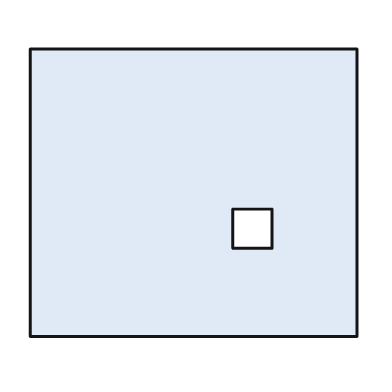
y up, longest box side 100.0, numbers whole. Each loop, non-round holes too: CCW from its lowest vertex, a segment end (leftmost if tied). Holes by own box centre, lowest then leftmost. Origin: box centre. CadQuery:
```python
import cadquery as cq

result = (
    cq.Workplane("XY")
    .moveTo(-50.0, -44.0)
    .lineTo(50.0, -44.0)
    .lineTo(50.0, 44.0)
    .lineTo(-50.0, 44.0)
    .close()
    .moveTo(12.0, -17.0)
    .lineTo(24.0, -17.0)
    .lineTo(24.0, -5.0)
    .lineTo(12.0, -5.0)
    .close()
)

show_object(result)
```